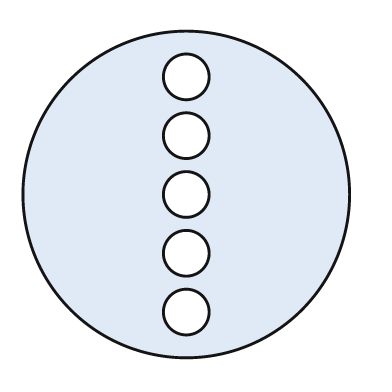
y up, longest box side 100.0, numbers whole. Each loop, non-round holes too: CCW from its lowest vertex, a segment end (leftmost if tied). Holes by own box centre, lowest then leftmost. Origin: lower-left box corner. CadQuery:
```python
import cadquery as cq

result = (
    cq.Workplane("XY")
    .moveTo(50.0, 50.0)
    .circle(50.0)
    .moveTo(50.0, 14.0)
    .circle(7.0)
    .moveTo(50.0, 32.0)
    .circle(7.0)
    .moveTo(50.0, 50.0)
    .circle(7.0)
    .moveTo(50.0, 68.0)
    .circle(7.0)
    .moveTo(50.0, 86.0)
    .circle(7.0)
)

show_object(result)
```